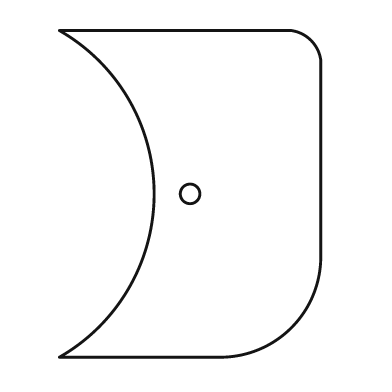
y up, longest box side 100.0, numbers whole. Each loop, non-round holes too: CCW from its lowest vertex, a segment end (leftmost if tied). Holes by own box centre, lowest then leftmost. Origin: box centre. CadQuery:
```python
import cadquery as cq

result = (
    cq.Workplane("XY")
    .moveTo(-40.0, -50.0)
    .lineTo(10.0, -50.0)
    .threePointArc((31.0, -41.0), (40.0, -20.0))
    .lineTo(40.0, 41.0)
    .threePointArc((37.0, 47.0), (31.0, 50.0))
    .lineTo(-40.0, 50.0)
    .threePointArc((-11.0, 0.0), (-40.0, -50.0))
    .close()
    .moveTo(0.0, 0.0)
    .circle(3.0)
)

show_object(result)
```